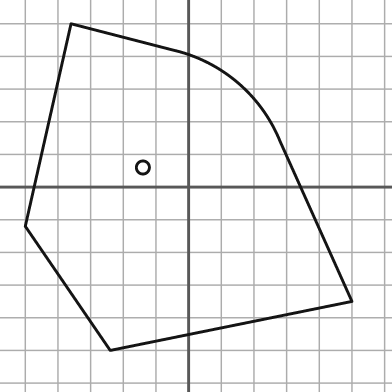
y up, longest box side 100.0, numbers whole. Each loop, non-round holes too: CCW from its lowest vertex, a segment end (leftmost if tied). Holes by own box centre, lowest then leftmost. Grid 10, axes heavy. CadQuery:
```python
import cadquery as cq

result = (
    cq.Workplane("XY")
    .moveTo(-24.0, -50.0)
    .lineTo(50.0, -35.0)
    .lineTo(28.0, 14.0)
    .threePointArc((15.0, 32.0), (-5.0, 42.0))
    .lineTo(-36.0, 50.0)
    .lineTo(-50.0, -12.0)
    .close()
    .moveTo(-14.0, 6.0)
    .circle(2.0)
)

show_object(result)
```